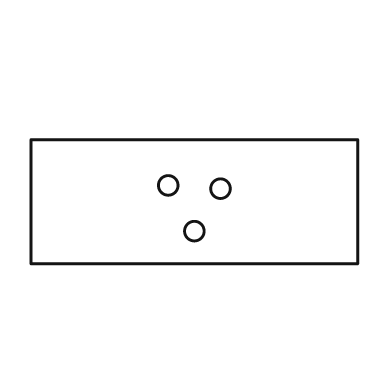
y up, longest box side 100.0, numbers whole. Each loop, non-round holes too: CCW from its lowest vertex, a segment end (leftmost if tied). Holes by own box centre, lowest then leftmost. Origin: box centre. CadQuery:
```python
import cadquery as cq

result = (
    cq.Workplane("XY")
    .moveTo(-50.0, -19.0)
    .lineTo(50.0, -19.0)
    .lineTo(50.0, 19.0)
    .lineTo(-50.0, 19.0)
    .close()
    .moveTo(0.0, -9.0)
    .circle(3.0)
    .moveTo(8.0, 4.0)
    .circle(3.0)
    .moveTo(-8.0, 5.0)
    .circle(3.0)
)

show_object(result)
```